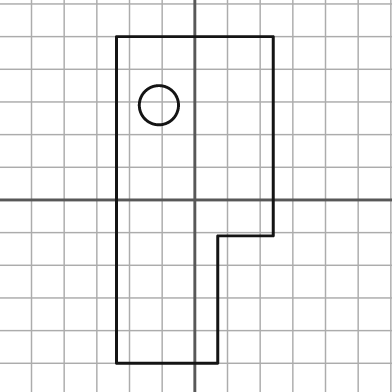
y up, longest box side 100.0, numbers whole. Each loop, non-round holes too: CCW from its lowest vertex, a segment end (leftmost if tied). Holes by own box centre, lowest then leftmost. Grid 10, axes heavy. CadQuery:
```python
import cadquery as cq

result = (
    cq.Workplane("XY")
    .moveTo(-24.0, -50.0)
    .lineTo(7.0, -50.0)
    .lineTo(7.0, -11.0)
    .lineTo(24.0, -11.0)
    .lineTo(24.0, 50.0)
    .lineTo(-24.0, 50.0)
    .close()
    .moveTo(-11.0, 29.0)
    .circle(6.0)
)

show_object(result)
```